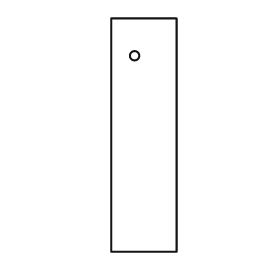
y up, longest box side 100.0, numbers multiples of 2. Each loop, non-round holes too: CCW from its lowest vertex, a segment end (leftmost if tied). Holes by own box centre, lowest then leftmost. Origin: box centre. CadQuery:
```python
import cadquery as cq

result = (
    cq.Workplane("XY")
    .moveTo(-14.0, -50.0)
    .lineTo(14.0, -50.0)
    .lineTo(14.0, 50.0)
    .lineTo(-14.0, 50.0)
    .close()
    .moveTo(-4.0, 34.0)
    .circle(2.0)
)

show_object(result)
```